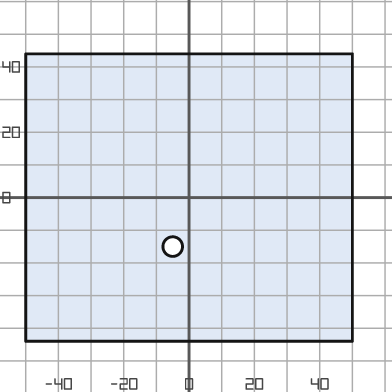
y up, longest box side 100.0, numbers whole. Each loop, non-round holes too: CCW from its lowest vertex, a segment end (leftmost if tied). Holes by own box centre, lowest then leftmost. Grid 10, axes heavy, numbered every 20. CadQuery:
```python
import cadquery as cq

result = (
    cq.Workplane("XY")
    .moveTo(-50.0, -44.0)
    .lineTo(50.0, -44.0)
    .lineTo(50.0, 44.0)
    .lineTo(-50.0, 44.0)
    .close()
    .moveTo(-5.0, -15.0)
    .circle(3.0)
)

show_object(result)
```